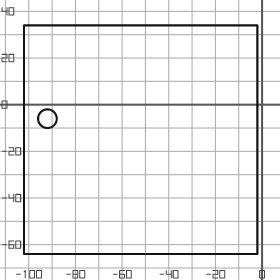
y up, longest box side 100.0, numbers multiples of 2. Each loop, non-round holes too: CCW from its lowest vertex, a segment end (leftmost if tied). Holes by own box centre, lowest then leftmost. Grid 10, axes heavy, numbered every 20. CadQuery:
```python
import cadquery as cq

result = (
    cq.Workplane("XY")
    .moveTo(-102.0, -64.0)
    .lineTo(-2.0, -64.0)
    .lineTo(-2.0, 34.0)
    .lineTo(-102.0, 34.0)
    .close()
    .moveTo(-92.0, -6.0)
    .circle(4.0)
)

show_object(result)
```